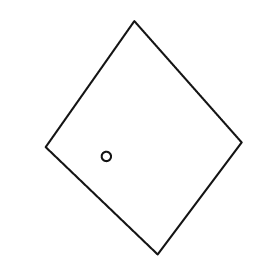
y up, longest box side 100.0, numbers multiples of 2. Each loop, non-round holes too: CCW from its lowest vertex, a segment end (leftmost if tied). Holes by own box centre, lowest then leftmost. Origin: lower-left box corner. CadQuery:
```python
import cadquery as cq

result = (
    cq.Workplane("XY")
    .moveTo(48.0, 0.0)
    .lineTo(84.0, 48.0)
    .lineTo(38.0, 100.0)
    .lineTo(0.0, 46.0)
    .close()
    .moveTo(26.0, 42.0)
    .circle(2.0)
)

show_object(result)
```